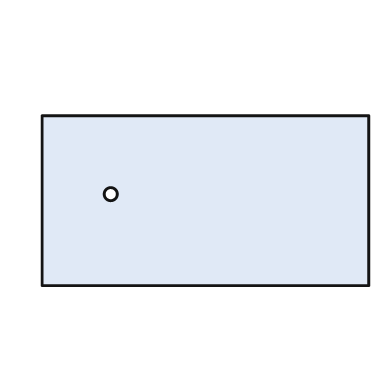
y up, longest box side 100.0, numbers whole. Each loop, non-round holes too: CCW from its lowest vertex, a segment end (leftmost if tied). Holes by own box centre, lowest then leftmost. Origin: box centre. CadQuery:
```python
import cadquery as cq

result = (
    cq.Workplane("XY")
    .moveTo(-50.0, -26.0)
    .lineTo(50.0, -26.0)
    .lineTo(50.0, 26.0)
    .lineTo(-50.0, 26.0)
    .close()
    .moveTo(-29.0, 2.0)
    .circle(2.0)
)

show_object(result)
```